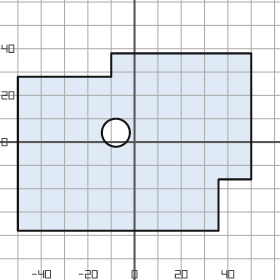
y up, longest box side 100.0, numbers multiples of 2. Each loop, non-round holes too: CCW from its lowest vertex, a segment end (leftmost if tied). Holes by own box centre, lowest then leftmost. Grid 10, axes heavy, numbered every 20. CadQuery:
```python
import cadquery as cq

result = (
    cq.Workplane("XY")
    .moveTo(-50.0, -38.0)
    .lineTo(36.0, -38.0)
    .lineTo(36.0, -16.0)
    .lineTo(50.0, -16.0)
    .lineTo(50.0, 38.0)
    .lineTo(-10.0, 38.0)
    .lineTo(-10.0, 28.0)
    .lineTo(-50.0, 28.0)
    .close()
    .moveTo(-8.0, 4.0)
    .circle(6.0)
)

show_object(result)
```